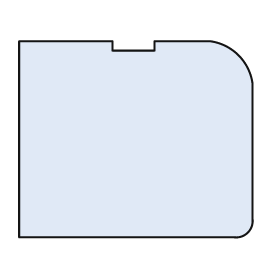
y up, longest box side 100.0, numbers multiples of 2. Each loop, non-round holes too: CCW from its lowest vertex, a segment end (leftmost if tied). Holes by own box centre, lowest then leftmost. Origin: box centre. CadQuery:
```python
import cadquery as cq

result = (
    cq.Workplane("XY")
    .moveTo(-50.0, -42.0)
    .lineTo(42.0, -42.0)
    .threePointArc((48.0, -40.0), (50.0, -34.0))
    .lineTo(50.0, 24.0)
    .threePointArc((44.0, 36.0), (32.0, 42.0))
    .lineTo(8.0, 42.0)
    .lineTo(8.0, 38.0)
    .lineTo(-10.0, 38.0)
    .lineTo(-10.0, 42.0)
    .lineTo(-50.0, 42.0)
    .close()
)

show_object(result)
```